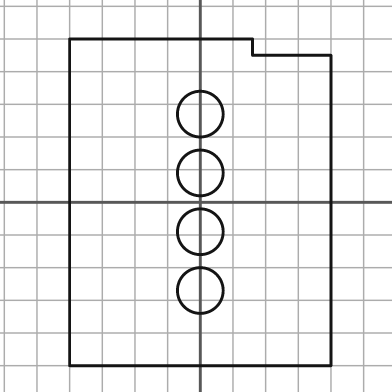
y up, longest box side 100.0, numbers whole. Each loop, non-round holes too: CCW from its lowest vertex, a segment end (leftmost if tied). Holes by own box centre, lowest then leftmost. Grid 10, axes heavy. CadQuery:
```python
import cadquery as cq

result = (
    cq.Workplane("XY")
    .moveTo(-40.0, -50.0)
    .lineTo(40.0, -50.0)
    .lineTo(40.0, 45.0)
    .lineTo(16.0, 45.0)
    .lineTo(16.0, 50.0)
    .lineTo(-40.0, 50.0)
    .close()
    .moveTo(0.0, -27.0)
    .circle(7.0)
    .moveTo(0.0, -9.0)
    .circle(7.0)
    .moveTo(0.0, 9.0)
    .circle(7.0)
    .moveTo(0.0, 27.0)
    .circle(7.0)
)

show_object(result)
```